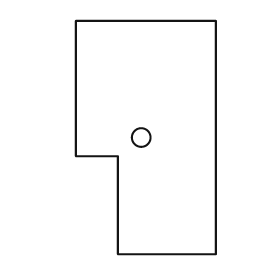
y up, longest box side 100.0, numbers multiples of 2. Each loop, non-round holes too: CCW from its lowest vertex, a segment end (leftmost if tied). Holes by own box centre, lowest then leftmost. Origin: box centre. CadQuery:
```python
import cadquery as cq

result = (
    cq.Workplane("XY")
    .moveTo(-12.0, -50.0)
    .lineTo(30.0, -50.0)
    .lineTo(30.0, 50.0)
    .lineTo(-30.0, 50.0)
    .lineTo(-30.0, -8.0)
    .lineTo(-12.0, -8.0)
    .close()
    .moveTo(-2.0, 0.0)
    .circle(4.0)
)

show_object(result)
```